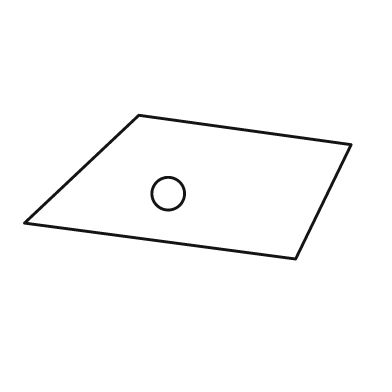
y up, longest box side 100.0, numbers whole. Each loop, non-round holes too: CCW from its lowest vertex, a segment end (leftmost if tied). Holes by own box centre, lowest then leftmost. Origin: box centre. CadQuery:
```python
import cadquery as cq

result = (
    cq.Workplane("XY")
    .moveTo(33.0, -22.0)
    .lineTo(50.0, 13.0)
    .lineTo(-15.0, 22.0)
    .lineTo(-50.0, -11.0)
    .close()
    .moveTo(-6.0, -2.0)
    .circle(5.0)
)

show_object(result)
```